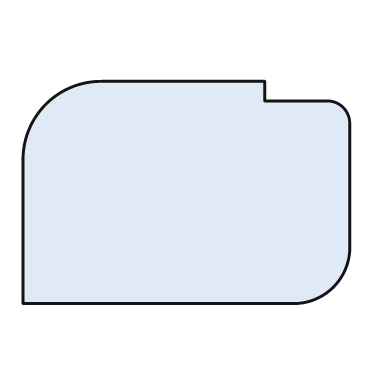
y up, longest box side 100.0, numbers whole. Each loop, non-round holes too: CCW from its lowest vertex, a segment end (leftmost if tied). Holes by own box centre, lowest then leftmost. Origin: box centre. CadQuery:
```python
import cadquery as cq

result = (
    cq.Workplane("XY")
    .moveTo(-50.0, -34.0)
    .lineTo(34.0, -34.0)
    .threePointArc((45.0, -29.0), (50.0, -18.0))
    .lineTo(50.0, 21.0)
    .threePointArc((48.0, 26.0), (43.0, 28.0))
    .lineTo(24.0, 28.0)
    .lineTo(24.0, 34.0)
    .lineTo(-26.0, 34.0)
    .threePointArc((-43.0, 27.0), (-50.0, 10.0))
    .close()
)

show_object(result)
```